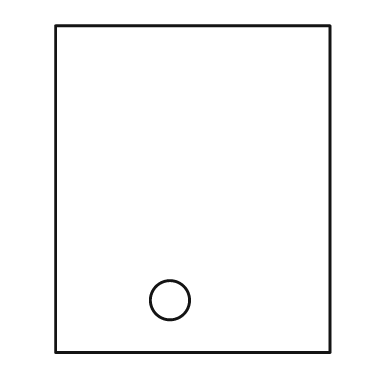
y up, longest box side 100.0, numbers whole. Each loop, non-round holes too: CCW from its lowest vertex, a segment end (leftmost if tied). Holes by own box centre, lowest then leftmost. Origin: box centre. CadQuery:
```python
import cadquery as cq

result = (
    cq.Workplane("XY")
    .moveTo(-42.0, -50.0)
    .lineTo(42.0, -50.0)
    .lineTo(42.0, 50.0)
    .lineTo(-42.0, 50.0)
    .close()
    .moveTo(-7.0, -34.0)
    .circle(6.0)
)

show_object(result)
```